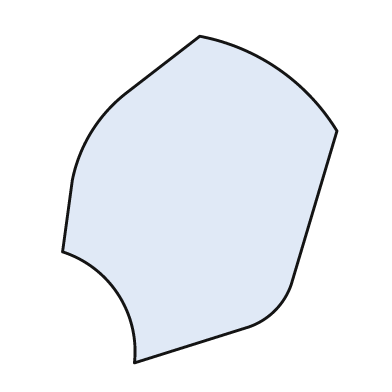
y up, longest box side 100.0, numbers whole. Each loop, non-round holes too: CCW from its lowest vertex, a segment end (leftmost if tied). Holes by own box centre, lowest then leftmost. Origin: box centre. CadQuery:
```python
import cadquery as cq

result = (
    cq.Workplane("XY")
    .moveTo(-20.0, -50.0)
    .lineTo(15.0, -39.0)
    .threePointArc((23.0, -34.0), (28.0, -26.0))
    .lineTo(42.0, 21.0)
    .threePointArc((24.0, 40.0), (0.0, 50.0))
    .lineTo(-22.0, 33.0)
    .threePointArc((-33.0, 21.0), (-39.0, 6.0))
    .lineTo(-42.0, -16.0)
    .threePointArc((-25.0, -29.0), (-20.0, -50.0))
    .close()
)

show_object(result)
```